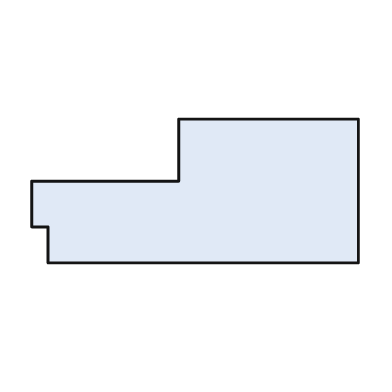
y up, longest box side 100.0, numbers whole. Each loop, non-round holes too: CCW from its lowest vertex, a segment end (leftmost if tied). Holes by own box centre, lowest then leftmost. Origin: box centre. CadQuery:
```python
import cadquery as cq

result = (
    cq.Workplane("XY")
    .moveTo(-45.0, -22.0)
    .lineTo(50.0, -22.0)
    .lineTo(50.0, 22.0)
    .lineTo(-5.0, 22.0)
    .lineTo(-5.0, 3.0)
    .lineTo(-50.0, 3.0)
    .lineTo(-50.0, -11.0)
    .lineTo(-45.0, -11.0)
    .close()
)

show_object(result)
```